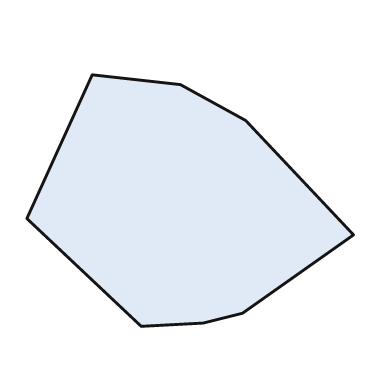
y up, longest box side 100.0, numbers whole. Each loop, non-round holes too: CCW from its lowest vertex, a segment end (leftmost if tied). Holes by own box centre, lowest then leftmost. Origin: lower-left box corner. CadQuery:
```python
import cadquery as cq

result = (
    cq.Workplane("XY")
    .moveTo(35.0, 0.0)
    .lineTo(54.0, 1.0)
    .lineTo(66.0, 4.0)
    .lineTo(100.0, 28.0)
    .lineTo(67.0, 63.0)
    .lineTo(47.0, 74.0)
    .lineTo(20.0, 77.0)
    .lineTo(0.0, 33.0)
    .close()
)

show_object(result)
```